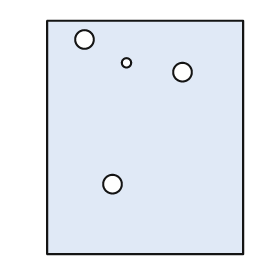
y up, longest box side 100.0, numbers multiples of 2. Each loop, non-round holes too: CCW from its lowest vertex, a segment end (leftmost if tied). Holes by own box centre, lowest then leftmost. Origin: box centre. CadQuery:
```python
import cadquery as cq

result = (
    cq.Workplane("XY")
    .moveTo(-42.0, -50.0)
    .lineTo(42.0, -50.0)
    .lineTo(42.0, 50.0)
    .lineTo(-42.0, 50.0)
    .close()
    .moveTo(-14.0, -20.0)
    .circle(4.0)
    .moveTo(16.0, 28.0)
    .circle(4.0)
    .moveTo(-8.0, 32.0)
    .circle(2.0)
    .moveTo(-26.0, 42.0)
    .circle(4.0)
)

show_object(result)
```